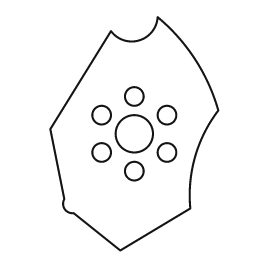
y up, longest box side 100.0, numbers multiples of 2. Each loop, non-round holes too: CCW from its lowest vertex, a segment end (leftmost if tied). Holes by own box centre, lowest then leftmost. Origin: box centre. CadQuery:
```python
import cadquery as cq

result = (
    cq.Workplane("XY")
    .moveTo(-6.0, -50.0)
    .lineTo(24.0, -32.0)
    .threePointArc((26.0, -10.0), (36.0, 10.0))
    .threePointArc((26.0, 32.0), (10.0, 50.0))
    .threePointArc((2.0, 40.0), (-10.0, 44.0))
    .lineTo(-36.0, 2.0)
    .lineTo(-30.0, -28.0)
    .threePointArc((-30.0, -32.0), (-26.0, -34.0))
    .close()
    .moveTo(0.0, -16.0)
    .circle(4.0)
    .moveTo(-14.0, -8.0)
    .circle(4.0)
    .moveTo(14.0, -8.0)
    .circle(4.0)
    .moveTo(0.0, 0.0)
    .circle(8.0)
    .moveTo(-14.0, 8.0)
    .circle(4.0)
    .moveTo(14.0, 8.0)
    .circle(4.0)
    .moveTo(0.0, 16.0)
    .circle(4.0)
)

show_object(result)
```